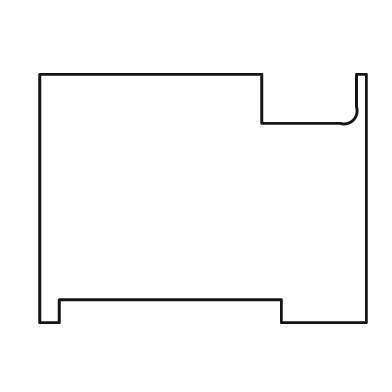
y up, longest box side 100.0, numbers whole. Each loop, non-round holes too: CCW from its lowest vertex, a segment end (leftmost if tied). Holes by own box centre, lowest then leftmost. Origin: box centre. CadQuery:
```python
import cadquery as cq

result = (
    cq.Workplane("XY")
    .moveTo(-50.0, -38.0)
    .lineTo(-44.0, -38.0)
    .lineTo(-44.0, -31.0)
    .lineTo(24.0, -31.0)
    .lineTo(24.0, -38.0)
    .lineTo(50.0, -38.0)
    .lineTo(50.0, 38.0)
    .lineTo(47.0, 38.0)
    .lineTo(47.0, 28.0)
    .threePointArc((46.0, 24.0), (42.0, 23.0))
    .lineTo(18.0, 23.0)
    .lineTo(18.0, 38.0)
    .lineTo(-50.0, 38.0)
    .close()
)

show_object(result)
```